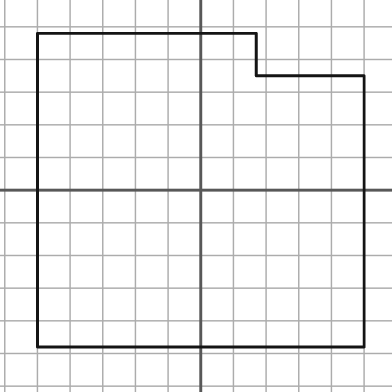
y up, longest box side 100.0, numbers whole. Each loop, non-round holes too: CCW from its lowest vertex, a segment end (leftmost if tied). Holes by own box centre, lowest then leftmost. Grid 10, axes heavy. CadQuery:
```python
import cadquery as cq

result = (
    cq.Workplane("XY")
    .moveTo(-50.0, -48.0)
    .lineTo(50.0, -48.0)
    .lineTo(50.0, 35.0)
    .lineTo(17.0, 35.0)
    .lineTo(17.0, 48.0)
    .lineTo(-50.0, 48.0)
    .close()
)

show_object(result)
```